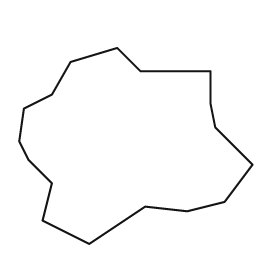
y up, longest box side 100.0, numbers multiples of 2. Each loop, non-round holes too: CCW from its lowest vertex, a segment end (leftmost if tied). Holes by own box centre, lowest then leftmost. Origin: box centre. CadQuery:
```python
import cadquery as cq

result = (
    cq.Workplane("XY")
    .moveTo(-20.0, -42.0)
    .lineTo(4.0, -26.0)
    .lineTo(22.0, -28.0)
    .lineTo(38.0, -24.0)
    .lineTo(50.0, -8.0)
    .lineTo(34.0, 8.0)
    .lineTo(32.0, 18.0)
    .lineTo(32.0, 32.0)
    .lineTo(2.0, 32.0)
    .lineTo(-8.0, 42.0)
    .lineTo(-28.0, 36.0)
    .lineTo(-36.0, 22.0)
    .lineTo(-48.0, 16.0)
    .lineTo(-50.0, 2.0)
    .lineTo(-46.0, -6.0)
    .lineTo(-36.0, -16.0)
    .lineTo(-40.0, -32.0)
    .close()
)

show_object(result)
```